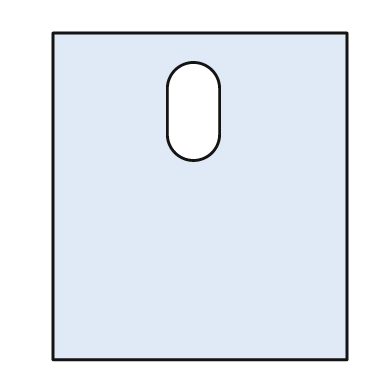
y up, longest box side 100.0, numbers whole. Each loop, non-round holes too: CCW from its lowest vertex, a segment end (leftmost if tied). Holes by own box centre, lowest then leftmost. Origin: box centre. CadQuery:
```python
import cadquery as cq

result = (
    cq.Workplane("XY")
    .moveTo(-45.0, -50.0)
    .lineTo(45.0, -50.0)
    .lineTo(45.0, 50.0)
    .lineTo(-45.0, 50.0)
    .close()
    .moveTo(-10.0, 19.0)
    .threePointArc((-2.0, 11.0), (6.0, 19.0))
    .lineTo(6.0, 33.0)
    .threePointArc((-2.0, 41.0), (-10.0, 33.0))
    .close()
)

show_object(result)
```